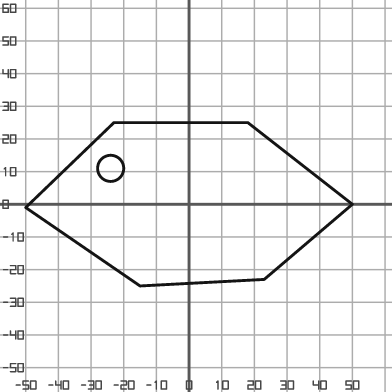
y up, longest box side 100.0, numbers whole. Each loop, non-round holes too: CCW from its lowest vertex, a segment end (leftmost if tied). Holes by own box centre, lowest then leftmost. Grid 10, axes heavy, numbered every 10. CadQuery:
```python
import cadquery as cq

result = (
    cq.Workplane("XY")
    .moveTo(-15.0, -25.0)
    .lineTo(23.0, -23.0)
    .lineTo(50.0, 0.0)
    .lineTo(18.0, 25.0)
    .lineTo(-23.0, 25.0)
    .lineTo(-50.0, -1.0)
    .close()
    .moveTo(-24.0, 11.0)
    .circle(4.0)
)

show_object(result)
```